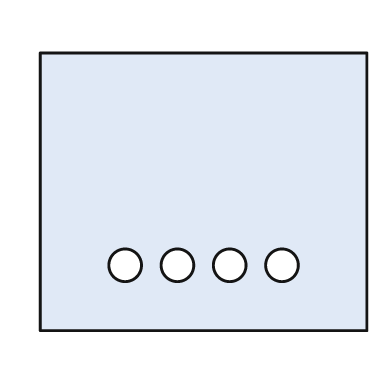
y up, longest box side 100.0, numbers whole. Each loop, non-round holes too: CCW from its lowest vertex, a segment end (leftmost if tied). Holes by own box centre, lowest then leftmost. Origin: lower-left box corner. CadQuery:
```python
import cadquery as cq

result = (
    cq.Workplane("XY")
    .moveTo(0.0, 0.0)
    .lineTo(100.0, 0.0)
    .lineTo(100.0, 85.0)
    .lineTo(0.0, 85.0)
    .close()
    .moveTo(26.0, 20.0)
    .circle(5.0)
    .moveTo(42.0, 20.0)
    .circle(5.0)
    .moveTo(58.0, 20.0)
    .circle(5.0)
    .moveTo(74.0, 20.0)
    .circle(5.0)
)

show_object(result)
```